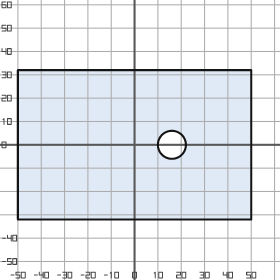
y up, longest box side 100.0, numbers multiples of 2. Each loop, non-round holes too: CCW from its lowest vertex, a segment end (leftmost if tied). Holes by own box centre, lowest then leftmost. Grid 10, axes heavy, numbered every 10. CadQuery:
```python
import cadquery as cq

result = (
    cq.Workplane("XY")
    .moveTo(-50.0, -32.0)
    .lineTo(50.0, -32.0)
    .lineTo(50.0, 32.0)
    .lineTo(-50.0, 32.0)
    .close()
    .moveTo(16.0, 0.0)
    .circle(6.0)
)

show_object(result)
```